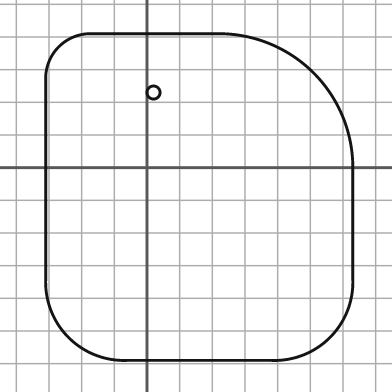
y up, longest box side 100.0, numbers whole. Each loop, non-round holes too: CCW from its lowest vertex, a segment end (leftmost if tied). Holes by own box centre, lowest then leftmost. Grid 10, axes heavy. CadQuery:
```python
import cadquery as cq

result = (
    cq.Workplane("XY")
    .moveTo(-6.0, -59.0)
    .lineTo(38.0, -59.0)
    .threePointArc((56.0, -52.0), (63.0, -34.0))
    .lineTo(63.0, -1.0)
    .threePointArc((51.0, 29.0), (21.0, 41.0))
    .lineTo(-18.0, 41.0)
    .threePointArc((-27.0, 37.0), (-31.0, 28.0))
    .lineTo(-31.0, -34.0)
    .threePointArc((-24.0, -52.0), (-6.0, -59.0))
    .close()
    .moveTo(2.0, 23.0)
    .circle(2.0)
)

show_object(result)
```